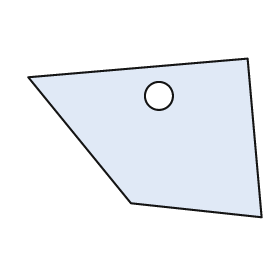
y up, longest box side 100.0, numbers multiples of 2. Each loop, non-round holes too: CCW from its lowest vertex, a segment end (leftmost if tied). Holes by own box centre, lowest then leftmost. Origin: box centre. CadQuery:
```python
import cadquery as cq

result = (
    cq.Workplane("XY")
    .moveTo(50.0, -34.0)
    .lineTo(44.0, 34.0)
    .lineTo(-50.0, 26.0)
    .lineTo(-6.0, -28.0)
    .close()
    .moveTo(6.0, 18.0)
    .circle(6.0)
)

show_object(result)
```